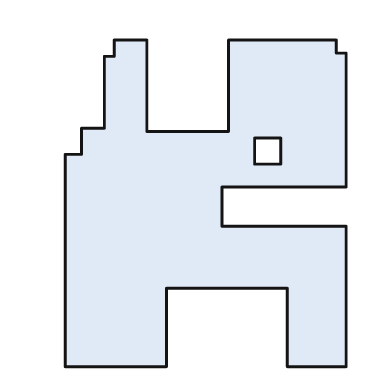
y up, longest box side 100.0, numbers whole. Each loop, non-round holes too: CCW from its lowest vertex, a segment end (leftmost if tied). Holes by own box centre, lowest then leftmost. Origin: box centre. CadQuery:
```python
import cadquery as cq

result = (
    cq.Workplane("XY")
    .moveTo(-43.0, -50.0)
    .lineTo(-12.0, -50.0)
    .lineTo(-12.0, -26.0)
    .lineTo(25.0, -26.0)
    .lineTo(25.0, -50.0)
    .lineTo(43.0, -50.0)
    .lineTo(43.0, -7.0)
    .lineTo(5.0, -7.0)
    .lineTo(5.0, 5.0)
    .lineTo(43.0, 5.0)
    .lineTo(43.0, 46.0)
    .lineTo(40.0, 46.0)
    .lineTo(40.0, 50.0)
    .lineTo(7.0, 50.0)
    .lineTo(7.0, 22.0)
    .lineTo(-18.0, 22.0)
    .lineTo(-18.0, 50.0)
    .lineTo(-28.0, 50.0)
    .lineTo(-28.0, 45.0)
    .lineTo(-31.0, 45.0)
    .lineTo(-31.0, 23.0)
    .lineTo(-38.0, 23.0)
    .lineTo(-38.0, 15.0)
    .lineTo(-43.0, 15.0)
    .close()
    .moveTo(15.0, 12.0)
    .lineTo(23.0, 12.0)
    .lineTo(23.0, 20.0)
    .lineTo(15.0, 20.0)
    .close()
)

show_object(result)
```